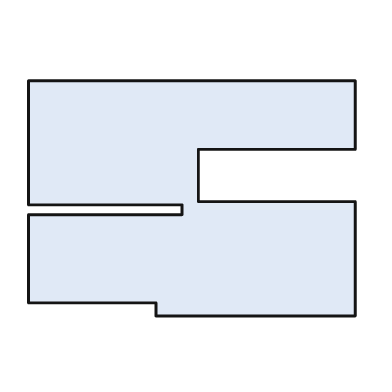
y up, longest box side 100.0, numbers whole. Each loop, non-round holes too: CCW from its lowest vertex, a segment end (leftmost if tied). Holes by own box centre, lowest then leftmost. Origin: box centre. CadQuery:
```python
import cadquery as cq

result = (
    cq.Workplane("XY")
    .moveTo(-11.0, -36.0)
    .lineTo(50.0, -36.0)
    .lineTo(50.0, -1.0)
    .lineTo(2.0, -1.0)
    .lineTo(2.0, 15.0)
    .lineTo(50.0, 15.0)
    .lineTo(50.0, 36.0)
    .lineTo(-50.0, 36.0)
    .lineTo(-50.0, -2.0)
    .lineTo(-3.0, -2.0)
    .lineTo(-3.0, -5.0)
    .lineTo(-50.0, -5.0)
    .lineTo(-50.0, -32.0)
    .lineTo(-11.0, -32.0)
    .close()
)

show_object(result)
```